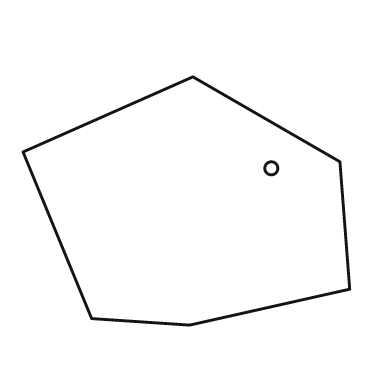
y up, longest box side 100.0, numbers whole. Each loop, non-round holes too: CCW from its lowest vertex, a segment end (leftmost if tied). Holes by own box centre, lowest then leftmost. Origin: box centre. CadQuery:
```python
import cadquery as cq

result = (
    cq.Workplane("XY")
    .moveTo(1.0, -38.0)
    .lineTo(50.0, -27.0)
    .lineTo(47.0, 12.0)
    .lineTo(2.0, 38.0)
    .lineTo(-50.0, 15.0)
    .lineTo(-29.0, -36.0)
    .close()
    .moveTo(26.0, 10.0)
    .circle(2.0)
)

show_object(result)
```